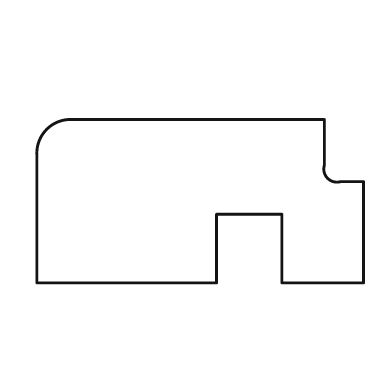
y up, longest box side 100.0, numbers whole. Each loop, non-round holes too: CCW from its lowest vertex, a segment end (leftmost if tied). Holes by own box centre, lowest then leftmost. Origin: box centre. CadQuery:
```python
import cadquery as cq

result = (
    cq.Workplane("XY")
    .moveTo(-50.0, -25.0)
    .lineTo(5.0, -25.0)
    .lineTo(5.0, -4.0)
    .lineTo(25.0, -4.0)
    .lineTo(25.0, -25.0)
    .lineTo(50.0, -25.0)
    .lineTo(50.0, 6.0)
    .lineTo(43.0, 6.0)
    .threePointArc((39.0, 7.0), (38.0, 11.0))
    .lineTo(38.0, 25.0)
    .lineTo(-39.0, 25.0)
    .threePointArc((-47.0, 22.0), (-50.0, 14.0))
    .close()
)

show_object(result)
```